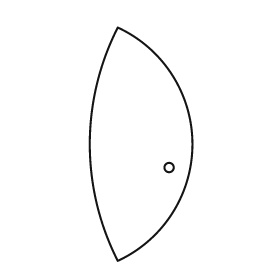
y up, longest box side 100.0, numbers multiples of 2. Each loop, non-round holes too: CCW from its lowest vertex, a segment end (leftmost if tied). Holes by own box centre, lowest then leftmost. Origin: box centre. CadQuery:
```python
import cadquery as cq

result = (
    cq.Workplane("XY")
    .moveTo(-10.0, -50.0)
    .threePointArc((22.0, 0.0), (-10.0, 50.0))
    .threePointArc((-22.0, 0.0), (-10.0, -50.0))
    .close()
    .moveTo(12.0, -10.0)
    .circle(2.0)
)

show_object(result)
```